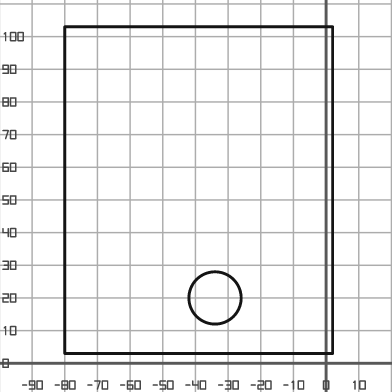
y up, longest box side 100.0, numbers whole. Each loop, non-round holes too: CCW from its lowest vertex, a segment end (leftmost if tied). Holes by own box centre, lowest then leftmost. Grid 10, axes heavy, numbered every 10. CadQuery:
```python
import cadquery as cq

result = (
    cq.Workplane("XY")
    .moveTo(-80.0, 3.0)
    .lineTo(2.0, 3.0)
    .lineTo(2.0, 103.0)
    .lineTo(-80.0, 103.0)
    .close()
    .moveTo(-34.0, 20.0)
    .circle(8.0)
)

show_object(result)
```